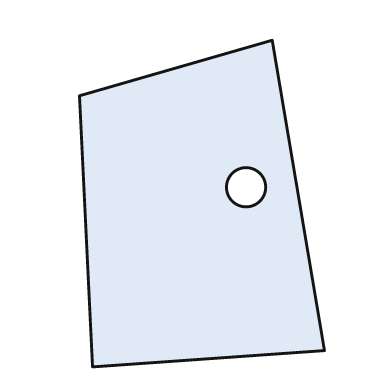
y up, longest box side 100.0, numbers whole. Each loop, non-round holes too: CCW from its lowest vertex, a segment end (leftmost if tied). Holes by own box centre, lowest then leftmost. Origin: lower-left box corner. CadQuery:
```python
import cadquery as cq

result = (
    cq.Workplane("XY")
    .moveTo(4.0, 0.0)
    .lineTo(75.0, 5.0)
    .lineTo(59.0, 100.0)
    .lineTo(0.0, 83.0)
    .close()
    .moveTo(51.0, 55.0)
    .circle(6.0)
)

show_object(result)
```